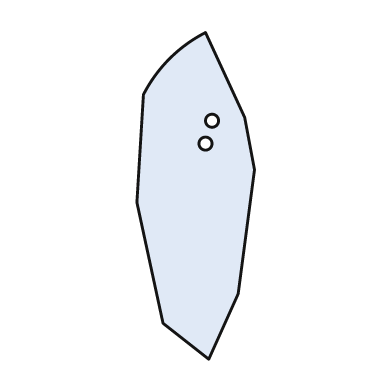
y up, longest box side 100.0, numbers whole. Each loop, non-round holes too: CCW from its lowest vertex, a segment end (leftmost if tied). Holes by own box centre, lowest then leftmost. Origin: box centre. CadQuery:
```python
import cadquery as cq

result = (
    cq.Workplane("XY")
    .moveTo(4.0, -50.0)
    .lineTo(13.0, -30.0)
    .lineTo(18.0, 8.0)
    .lineTo(15.0, 24.0)
    .lineTo(3.0, 50.0)
    .threePointArc((-8.0, 42.0), (-16.0, 31.0))
    .lineTo(-18.0, -2.0)
    .lineTo(-10.0, -39.0)
    .close()
    .moveTo(3.0, 16.0)
    .circle(2.0)
    .moveTo(5.0, 23.0)
    .circle(2.0)
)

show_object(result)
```